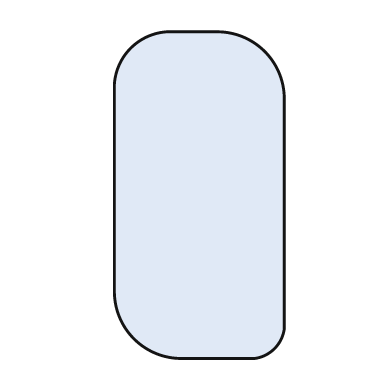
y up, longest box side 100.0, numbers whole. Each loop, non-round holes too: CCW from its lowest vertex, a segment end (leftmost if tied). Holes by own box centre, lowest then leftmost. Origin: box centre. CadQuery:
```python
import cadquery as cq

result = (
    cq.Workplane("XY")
    .moveTo(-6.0, -50.0)
    .lineTo(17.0, -50.0)
    .threePointArc((23.0, -47.0), (26.0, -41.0))
    .lineTo(26.0, 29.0)
    .threePointArc((20.0, 44.0), (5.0, 50.0))
    .lineTo(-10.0, 50.0)
    .threePointArc((-21.0, 45.0), (-26.0, 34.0))
    .lineTo(-26.0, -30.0)
    .threePointArc((-20.0, -44.0), (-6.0, -50.0))
    .close()
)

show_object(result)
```